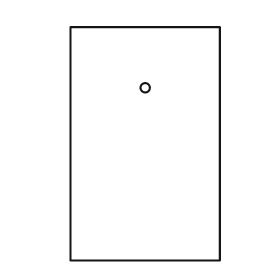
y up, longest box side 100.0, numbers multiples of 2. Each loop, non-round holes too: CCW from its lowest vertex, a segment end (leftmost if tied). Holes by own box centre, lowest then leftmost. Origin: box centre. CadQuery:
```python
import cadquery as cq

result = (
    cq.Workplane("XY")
    .moveTo(-32.0, -50.0)
    .lineTo(32.0, -50.0)
    .lineTo(32.0, 50.0)
    .lineTo(-32.0, 50.0)
    .close()
    .moveTo(0.0, 24.0)
    .circle(2.0)
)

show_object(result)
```